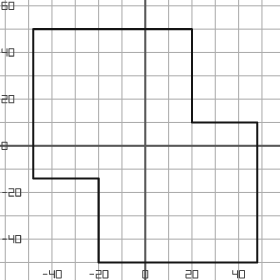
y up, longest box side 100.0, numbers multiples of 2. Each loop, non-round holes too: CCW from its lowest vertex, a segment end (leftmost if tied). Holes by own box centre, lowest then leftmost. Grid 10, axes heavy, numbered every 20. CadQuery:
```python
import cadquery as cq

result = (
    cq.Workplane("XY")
    .moveTo(-20.0, -50.0)
    .lineTo(48.0, -50.0)
    .lineTo(48.0, 10.0)
    .lineTo(20.0, 10.0)
    .lineTo(20.0, 50.0)
    .lineTo(-48.0, 50.0)
    .lineTo(-48.0, -14.0)
    .lineTo(-20.0, -14.0)
    .close()
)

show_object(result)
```